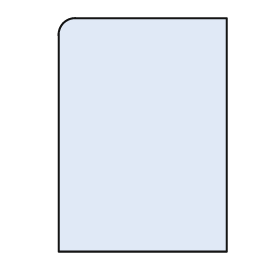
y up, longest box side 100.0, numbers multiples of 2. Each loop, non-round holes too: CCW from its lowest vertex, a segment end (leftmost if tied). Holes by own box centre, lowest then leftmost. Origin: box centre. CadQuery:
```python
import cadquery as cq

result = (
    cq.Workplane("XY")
    .moveTo(-36.0, -50.0)
    .lineTo(36.0, -50.0)
    .lineTo(36.0, 50.0)
    .lineTo(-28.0, 50.0)
    .threePointArc((-34.0, 48.0), (-36.0, 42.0))
    .close()
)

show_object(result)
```